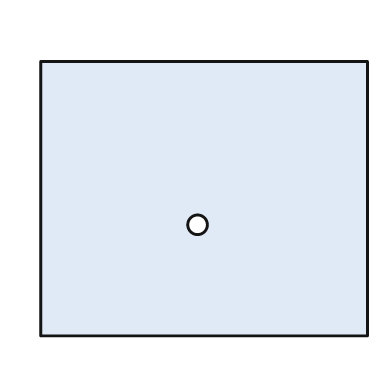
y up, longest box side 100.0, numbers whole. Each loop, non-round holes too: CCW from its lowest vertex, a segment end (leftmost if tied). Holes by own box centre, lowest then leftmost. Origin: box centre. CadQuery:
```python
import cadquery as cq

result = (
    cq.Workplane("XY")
    .moveTo(-50.0, -42.0)
    .lineTo(50.0, -42.0)
    .lineTo(50.0, 42.0)
    .lineTo(-50.0, 42.0)
    .close()
    .moveTo(-2.0, -8.0)
    .circle(3.0)
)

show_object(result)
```